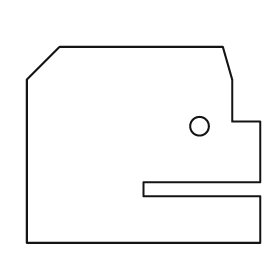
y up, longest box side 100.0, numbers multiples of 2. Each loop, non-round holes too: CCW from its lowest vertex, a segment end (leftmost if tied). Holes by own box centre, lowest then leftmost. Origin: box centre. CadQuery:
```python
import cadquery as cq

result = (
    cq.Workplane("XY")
    .moveTo(-50.0, -42.0)
    .lineTo(50.0, -42.0)
    .lineTo(50.0, -22.0)
    .lineTo(0.0, -22.0)
    .lineTo(0.0, -16.0)
    .lineTo(50.0, -16.0)
    .lineTo(50.0, 10.0)
    .lineTo(38.0, 10.0)
    .lineTo(38.0, 28.0)
    .lineTo(34.0, 42.0)
    .lineTo(-36.0, 42.0)
    .lineTo(-50.0, 28.0)
    .close()
    .moveTo(24.0, 8.0)
    .circle(4.0)
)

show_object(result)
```